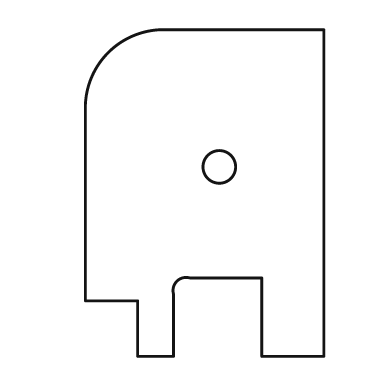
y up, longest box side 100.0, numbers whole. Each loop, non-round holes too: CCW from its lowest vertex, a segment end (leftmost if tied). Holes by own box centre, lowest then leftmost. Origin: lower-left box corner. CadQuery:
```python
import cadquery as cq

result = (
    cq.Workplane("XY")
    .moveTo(16.0, 0.0)
    .lineTo(27.0, 0.0)
    .lineTo(27.0, 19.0)
    .threePointArc((28.0, 23.0), (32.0, 24.0))
    .lineTo(54.0, 24.0)
    .lineTo(54.0, 0.0)
    .lineTo(73.0, 0.0)
    .lineTo(73.0, 100.0)
    .lineTo(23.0, 100.0)
    .threePointArc((7.0, 93.0), (0.0, 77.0))
    .lineTo(0.0, 17.0)
    .lineTo(16.0, 17.0)
    .close()
    .moveTo(41.0, 58.0)
    .circle(5.0)
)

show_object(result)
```